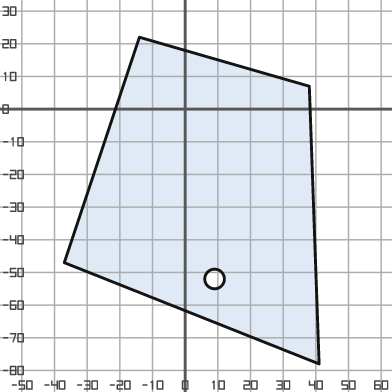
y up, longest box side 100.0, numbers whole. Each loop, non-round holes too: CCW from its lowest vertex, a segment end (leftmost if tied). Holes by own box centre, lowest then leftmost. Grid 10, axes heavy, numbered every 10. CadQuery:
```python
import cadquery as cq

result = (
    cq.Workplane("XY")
    .moveTo(41.0, -78.0)
    .lineTo(38.0, 7.0)
    .lineTo(-14.0, 22.0)
    .lineTo(-37.0, -47.0)
    .close()
    .moveTo(9.0, -52.0)
    .circle(3.0)
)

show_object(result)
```